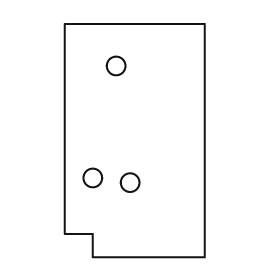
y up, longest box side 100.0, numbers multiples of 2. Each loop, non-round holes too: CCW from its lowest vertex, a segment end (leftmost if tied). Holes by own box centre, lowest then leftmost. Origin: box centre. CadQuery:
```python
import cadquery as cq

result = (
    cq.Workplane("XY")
    .moveTo(-18.0, -50.0)
    .lineTo(30.0, -50.0)
    .lineTo(30.0, 50.0)
    .lineTo(-30.0, 50.0)
    .lineTo(-30.0, -40.0)
    .lineTo(-18.0, -40.0)
    .close()
    .moveTo(-2.0, -18.0)
    .circle(4.0)
    .moveTo(-18.0, -16.0)
    .circle(4.0)
    .moveTo(-8.0, 32.0)
    .circle(4.0)
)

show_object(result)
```